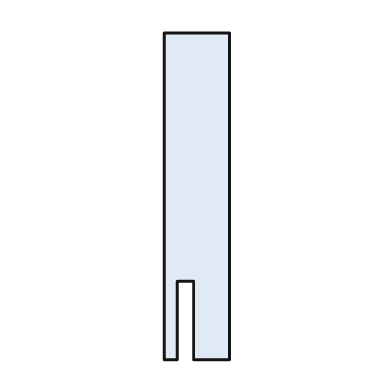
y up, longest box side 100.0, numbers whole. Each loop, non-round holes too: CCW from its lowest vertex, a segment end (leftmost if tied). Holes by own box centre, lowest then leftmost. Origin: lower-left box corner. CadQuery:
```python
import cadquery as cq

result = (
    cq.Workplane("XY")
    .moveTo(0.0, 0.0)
    .lineTo(4.0, 0.0)
    .lineTo(4.0, 24.0)
    .lineTo(9.0, 24.0)
    .lineTo(9.0, 0.0)
    .lineTo(20.0, 0.0)
    .lineTo(20.0, 100.0)
    .lineTo(0.0, 100.0)
    .close()
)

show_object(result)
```